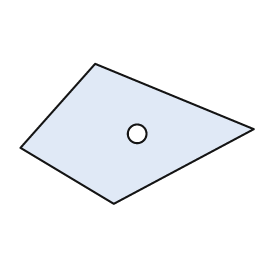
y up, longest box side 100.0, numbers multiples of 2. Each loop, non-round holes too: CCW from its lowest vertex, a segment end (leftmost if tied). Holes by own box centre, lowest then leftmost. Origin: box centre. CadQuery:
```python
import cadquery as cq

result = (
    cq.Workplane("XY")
    .moveTo(-10.0, -30.0)
    .lineTo(50.0, 2.0)
    .lineTo(-18.0, 30.0)
    .lineTo(-50.0, -6.0)
    .close()
    .moveTo(0.0, 0.0)
    .circle(4.0)
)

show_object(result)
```